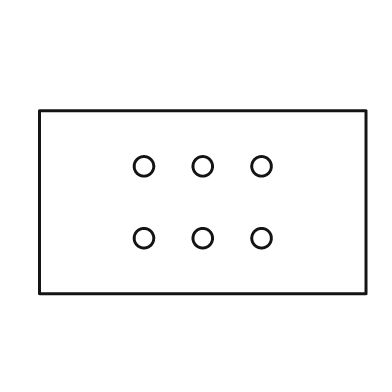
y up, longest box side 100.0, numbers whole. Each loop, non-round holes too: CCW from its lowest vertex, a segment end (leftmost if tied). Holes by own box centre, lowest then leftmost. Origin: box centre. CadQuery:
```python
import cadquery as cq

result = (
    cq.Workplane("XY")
    .moveTo(-50.0, -28.0)
    .lineTo(50.0, -28.0)
    .lineTo(50.0, 28.0)
    .lineTo(-50.0, 28.0)
    .close()
    .moveTo(-18.0, -11.0)
    .circle(3.0)
    .moveTo(0.0, -11.0)
    .circle(3.0)
    .moveTo(18.0, -11.0)
    .circle(3.0)
    .moveTo(-18.0, 11.0)
    .circle(3.0)
    .moveTo(0.0, 11.0)
    .circle(3.0)
    .moveTo(18.0, 11.0)
    .circle(3.0)
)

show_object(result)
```